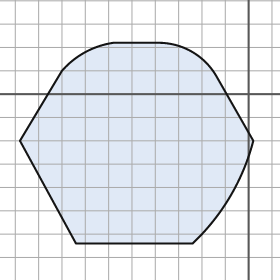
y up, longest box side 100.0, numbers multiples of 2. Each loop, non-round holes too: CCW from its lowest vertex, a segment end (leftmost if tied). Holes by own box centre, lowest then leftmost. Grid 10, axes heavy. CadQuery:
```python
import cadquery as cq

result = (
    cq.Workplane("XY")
    .moveTo(-74.0, -64.0)
    .lineTo(-24.0, -64.0)
    .threePointArc((-8.0, -44.0), (2.0, -20.0))
    .lineTo(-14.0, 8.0)
    .threePointArc((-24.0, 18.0), (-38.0, 22.0))
    .lineTo(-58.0, 22.0)
    .threePointArc((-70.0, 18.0), (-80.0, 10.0))
    .lineTo(-98.0, -20.0)
    .close()
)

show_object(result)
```